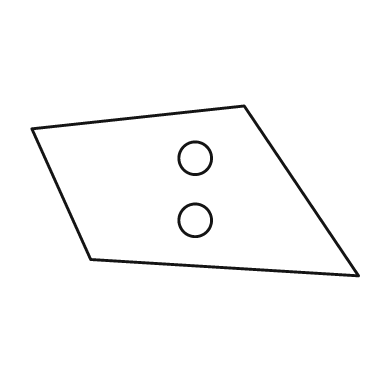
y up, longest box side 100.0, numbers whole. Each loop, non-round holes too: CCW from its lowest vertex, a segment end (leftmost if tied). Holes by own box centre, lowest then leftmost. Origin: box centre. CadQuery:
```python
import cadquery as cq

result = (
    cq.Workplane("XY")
    .moveTo(50.0, -26.0)
    .lineTo(15.0, 26.0)
    .lineTo(-50.0, 19.0)
    .lineTo(-32.0, -21.0)
    .close()
    .moveTo(0.0, -9.0)
    .circle(5.0)
    .moveTo(0.0, 10.0)
    .circle(5.0)
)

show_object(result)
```